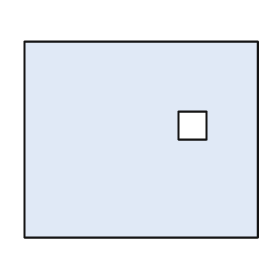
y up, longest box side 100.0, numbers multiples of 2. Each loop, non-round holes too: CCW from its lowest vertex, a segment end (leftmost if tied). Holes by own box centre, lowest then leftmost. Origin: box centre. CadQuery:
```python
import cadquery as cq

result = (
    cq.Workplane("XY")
    .moveTo(-50.0, -42.0)
    .lineTo(50.0, -42.0)
    .lineTo(50.0, 42.0)
    .lineTo(-50.0, 42.0)
    .close()
    .moveTo(16.0, 0.0)
    .lineTo(28.0, 0.0)
    .lineTo(28.0, 12.0)
    .lineTo(16.0, 12.0)
    .close()
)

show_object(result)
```